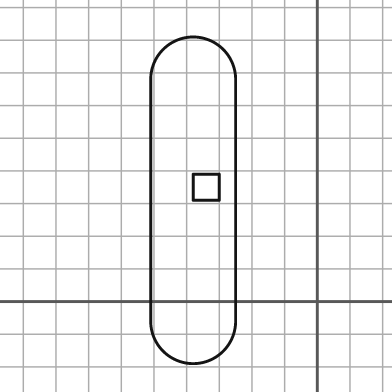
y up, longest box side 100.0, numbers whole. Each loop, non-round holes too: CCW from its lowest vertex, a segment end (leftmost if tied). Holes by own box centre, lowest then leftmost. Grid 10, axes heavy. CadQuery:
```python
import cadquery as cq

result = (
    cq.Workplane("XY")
    .moveTo(-51.0, -6.0)
    .threePointArc((-38.0, -19.0), (-25.0, -6.0))
    .lineTo(-25.0, 68.0)
    .threePointArc((-38.0, 81.0), (-51.0, 68.0))
    .close()
    .moveTo(-38.0, 31.0)
    .lineTo(-30.0, 31.0)
    .lineTo(-30.0, 39.0)
    .lineTo(-38.0, 39.0)
    .close()
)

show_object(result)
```